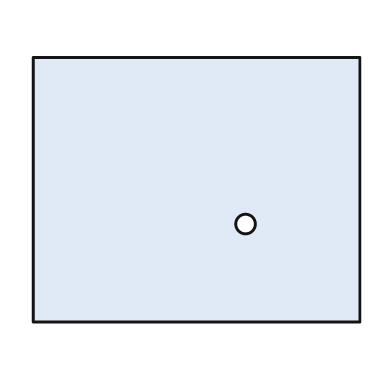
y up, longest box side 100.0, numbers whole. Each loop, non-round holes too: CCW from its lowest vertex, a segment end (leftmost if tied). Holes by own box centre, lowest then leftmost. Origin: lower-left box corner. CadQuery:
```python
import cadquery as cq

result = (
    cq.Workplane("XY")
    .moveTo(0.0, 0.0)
    .lineTo(100.0, 0.0)
    .lineTo(100.0, 81.0)
    .lineTo(0.0, 81.0)
    .close()
    .moveTo(65.0, 30.0)
    .circle(3.0)
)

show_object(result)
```